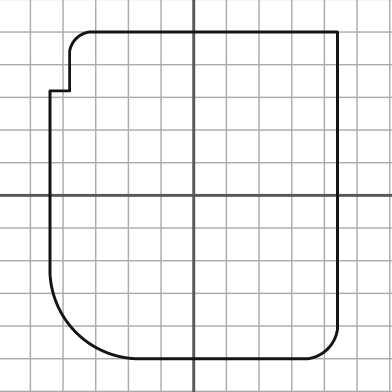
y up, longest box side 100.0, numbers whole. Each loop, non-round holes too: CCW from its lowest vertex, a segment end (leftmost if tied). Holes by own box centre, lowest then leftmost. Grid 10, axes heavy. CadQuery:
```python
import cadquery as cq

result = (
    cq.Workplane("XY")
    .moveTo(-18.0, -50.0)
    .lineTo(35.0, -50.0)
    .threePointArc((41.0, -47.0), (44.0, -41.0))
    .lineTo(44.0, 50.0)
    .lineTo(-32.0, 50.0)
    .threePointArc((-36.0, 48.0), (-38.0, 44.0))
    .lineTo(-38.0, 32.0)
    .lineTo(-44.0, 32.0)
    .lineTo(-44.0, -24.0)
    .threePointArc((-36.0, -42.0), (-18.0, -50.0))
    .close()
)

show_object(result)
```